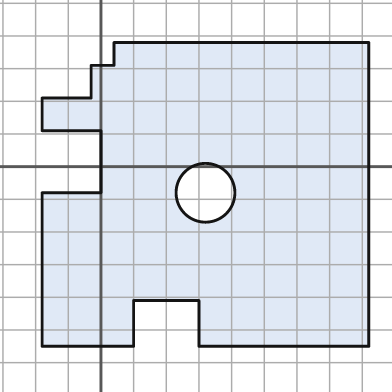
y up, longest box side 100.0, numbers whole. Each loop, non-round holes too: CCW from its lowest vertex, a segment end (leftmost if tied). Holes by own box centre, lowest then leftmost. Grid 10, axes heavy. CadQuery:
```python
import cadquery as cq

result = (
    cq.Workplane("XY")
    .moveTo(-18.0, -55.0)
    .lineTo(10.0, -55.0)
    .lineTo(10.0, -41.0)
    .lineTo(30.0, -41.0)
    .lineTo(30.0, -55.0)
    .lineTo(82.0, -55.0)
    .lineTo(82.0, 38.0)
    .lineTo(4.0, 38.0)
    .lineTo(4.0, 31.0)
    .lineTo(-3.0, 31.0)
    .lineTo(-3.0, 21.0)
    .lineTo(-18.0, 21.0)
    .lineTo(-18.0, 11.0)
    .lineTo(0.0, 11.0)
    .lineTo(0.0, -8.0)
    .lineTo(-18.0, -8.0)
    .close()
    .moveTo(32.0, -8.0)
    .circle(9.0)
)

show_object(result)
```